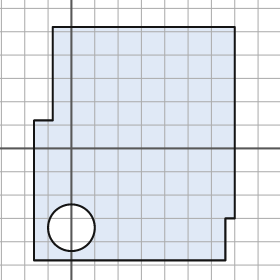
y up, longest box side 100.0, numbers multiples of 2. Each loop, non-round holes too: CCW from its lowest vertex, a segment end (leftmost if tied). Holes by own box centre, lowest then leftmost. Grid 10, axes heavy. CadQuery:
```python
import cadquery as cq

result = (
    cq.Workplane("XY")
    .moveTo(-16.0, -48.0)
    .lineTo(66.0, -48.0)
    .lineTo(66.0, -30.0)
    .lineTo(70.0, -30.0)
    .lineTo(70.0, 52.0)
    .lineTo(-8.0, 52.0)
    .lineTo(-8.0, 12.0)
    .lineTo(-16.0, 12.0)
    .close()
    .moveTo(0.0, -34.0)
    .circle(10.0)
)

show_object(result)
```